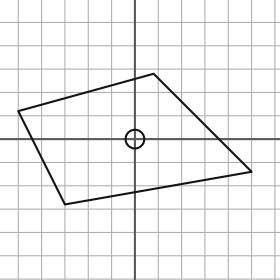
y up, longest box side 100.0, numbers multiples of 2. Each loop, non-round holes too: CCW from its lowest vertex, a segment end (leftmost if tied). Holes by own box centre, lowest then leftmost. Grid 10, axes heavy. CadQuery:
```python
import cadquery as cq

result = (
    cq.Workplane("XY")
    .moveTo(-30.0, -28.0)
    .lineTo(50.0, -14.0)
    .lineTo(8.0, 28.0)
    .lineTo(-50.0, 12.0)
    .close()
    .moveTo(0.0, 0.0)
    .circle(4.0)
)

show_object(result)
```